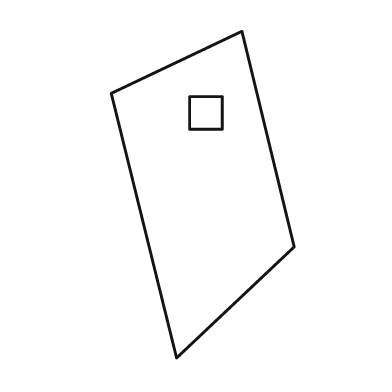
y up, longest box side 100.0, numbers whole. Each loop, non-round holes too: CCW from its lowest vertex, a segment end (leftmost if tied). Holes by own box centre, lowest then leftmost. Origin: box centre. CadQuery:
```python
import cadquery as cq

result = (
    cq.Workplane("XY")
    .moveTo(-8.0, -50.0)
    .lineTo(28.0, -16.0)
    .lineTo(12.0, 50.0)
    .lineTo(-28.0, 31.0)
    .close()
    .moveTo(-4.0, 20.0)
    .lineTo(6.0, 20.0)
    .lineTo(6.0, 30.0)
    .lineTo(-4.0, 30.0)
    .close()
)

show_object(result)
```